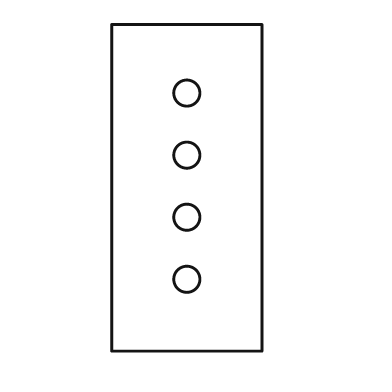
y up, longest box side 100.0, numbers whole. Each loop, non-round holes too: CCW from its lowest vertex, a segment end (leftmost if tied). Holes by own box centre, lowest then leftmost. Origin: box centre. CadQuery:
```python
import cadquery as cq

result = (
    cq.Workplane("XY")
    .moveTo(-23.0, -50.0)
    .lineTo(23.0, -50.0)
    .lineTo(23.0, 50.0)
    .lineTo(-23.0, 50.0)
    .close()
    .moveTo(0.0, -28.0)
    .circle(4.0)
    .moveTo(0.0, -9.0)
    .circle(4.0)
    .moveTo(0.0, 10.0)
    .circle(4.0)
    .moveTo(0.0, 29.0)
    .circle(4.0)
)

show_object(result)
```